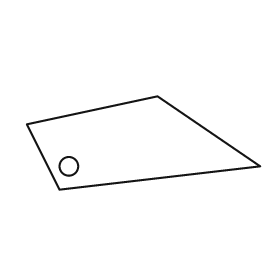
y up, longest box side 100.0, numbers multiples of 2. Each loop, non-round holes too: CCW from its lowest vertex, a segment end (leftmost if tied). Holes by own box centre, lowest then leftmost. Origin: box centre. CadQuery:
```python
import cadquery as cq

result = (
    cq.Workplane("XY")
    .moveTo(-36.0, -20.0)
    .lineTo(50.0, -10.0)
    .lineTo(6.0, 20.0)
    .lineTo(-50.0, 8.0)
    .close()
    .moveTo(-32.0, -10.0)
    .circle(4.0)
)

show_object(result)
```